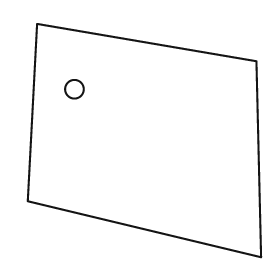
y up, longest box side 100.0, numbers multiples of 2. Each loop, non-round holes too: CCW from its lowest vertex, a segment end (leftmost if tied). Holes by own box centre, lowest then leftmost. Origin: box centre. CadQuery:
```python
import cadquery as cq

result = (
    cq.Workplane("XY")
    .moveTo(50.0, -50.0)
    .lineTo(48.0, 34.0)
    .lineTo(-46.0, 50.0)
    .lineTo(-50.0, -26.0)
    .close()
    .moveTo(-30.0, 22.0)
    .circle(4.0)
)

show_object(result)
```